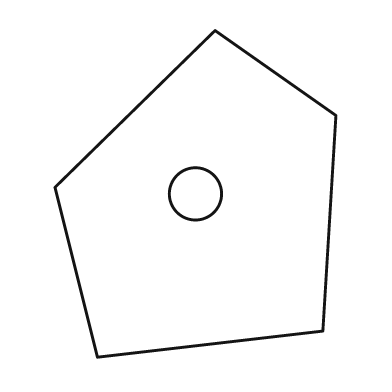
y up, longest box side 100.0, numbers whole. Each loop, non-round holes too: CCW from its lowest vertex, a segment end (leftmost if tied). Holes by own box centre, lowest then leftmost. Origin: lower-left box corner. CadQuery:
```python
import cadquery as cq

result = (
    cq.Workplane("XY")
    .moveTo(13.0, 0.0)
    .lineTo(82.0, 8.0)
    .lineTo(86.0, 74.0)
    .lineTo(49.0, 100.0)
    .lineTo(0.0, 52.0)
    .close()
    .moveTo(43.0, 50.0)
    .circle(8.0)
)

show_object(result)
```